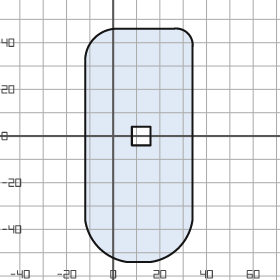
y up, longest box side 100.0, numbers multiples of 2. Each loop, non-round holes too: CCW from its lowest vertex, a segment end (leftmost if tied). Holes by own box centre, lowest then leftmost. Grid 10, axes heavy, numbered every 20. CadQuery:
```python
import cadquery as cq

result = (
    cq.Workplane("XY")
    .moveTo(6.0, -54.0)
    .lineTo(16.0, -54.0)
    .threePointArc((28.0, -48.0), (34.0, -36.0))
    .lineTo(34.0, 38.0)
    .threePointArc((32.0, 44.0), (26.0, 46.0))
    .lineTo(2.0, 46.0)
    .threePointArc((-8.0, 42.0), (-12.0, 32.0))
    .lineTo(-12.0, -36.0)
    .threePointArc((-6.0, -48.0), (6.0, -54.0))
    .close()
    .moveTo(8.0, -4.0)
    .lineTo(16.0, -4.0)
    .lineTo(16.0, 4.0)
    .lineTo(8.0, 4.0)
    .close()
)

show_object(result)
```